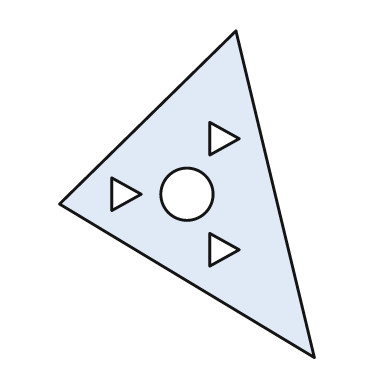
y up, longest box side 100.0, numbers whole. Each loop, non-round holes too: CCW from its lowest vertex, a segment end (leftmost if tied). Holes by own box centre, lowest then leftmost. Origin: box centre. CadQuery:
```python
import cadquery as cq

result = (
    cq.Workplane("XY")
    .moveTo(39.0, -50.0)
    .lineTo(15.0, 50.0)
    .lineTo(-39.0, -3.0)
    .close()
    .moveTo(7.0, -22.0)
    .lineTo(16.0, -17.0)
    .lineTo(7.0, -12.0)
    .close()
    .moveTo(-23.0, -5.0)
    .lineTo(-14.0, 0.0)
    .lineTo(-23.0, 5.0)
    .close()
    .moveTo(0.0, 0.0)
    .circle(8.0)
    .moveTo(7.0, 12.0)
    .lineTo(16.0, 17.0)
    .lineTo(7.0, 22.0)
    .close()
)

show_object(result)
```